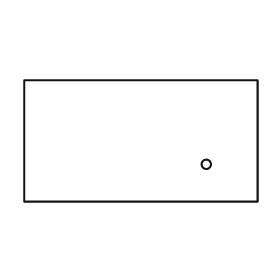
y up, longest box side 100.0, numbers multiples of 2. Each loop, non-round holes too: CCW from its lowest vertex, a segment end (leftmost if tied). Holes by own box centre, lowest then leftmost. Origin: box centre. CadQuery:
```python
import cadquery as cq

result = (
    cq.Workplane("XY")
    .moveTo(-50.0, -26.0)
    .lineTo(50.0, -26.0)
    .lineTo(50.0, 26.0)
    .lineTo(-50.0, 26.0)
    .close()
    .moveTo(28.0, -10.0)
    .circle(2.0)
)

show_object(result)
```